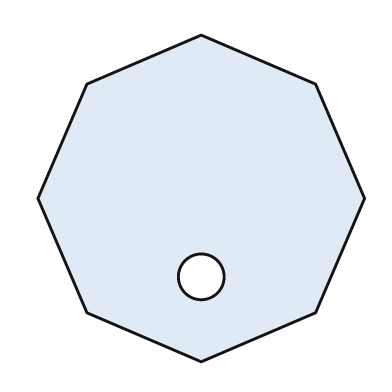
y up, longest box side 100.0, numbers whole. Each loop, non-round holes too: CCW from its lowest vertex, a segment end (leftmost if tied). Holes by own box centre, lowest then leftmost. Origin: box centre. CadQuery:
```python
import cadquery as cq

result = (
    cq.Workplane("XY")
    .moveTo(0.0, -50.0)
    .lineTo(35.0, -35.0)
    .lineTo(50.0, 0.0)
    .lineTo(35.0, 35.0)
    .lineTo(0.0, 50.0)
    .lineTo(-35.0, 35.0)
    .lineTo(-50.0, 0.0)
    .lineTo(-35.0, -35.0)
    .close()
    .moveTo(0.0, -24.0)
    .circle(7.0)
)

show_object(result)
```